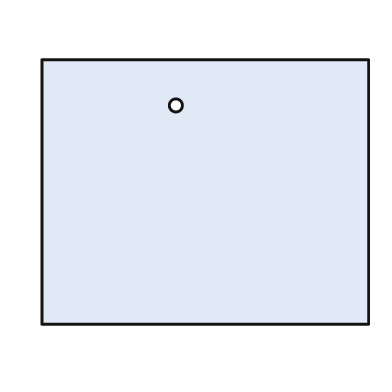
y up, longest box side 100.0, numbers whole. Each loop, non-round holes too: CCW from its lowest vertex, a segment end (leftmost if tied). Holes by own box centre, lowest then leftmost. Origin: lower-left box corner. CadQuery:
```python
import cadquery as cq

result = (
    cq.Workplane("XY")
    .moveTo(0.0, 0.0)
    .lineTo(100.0, 0.0)
    .lineTo(100.0, 81.0)
    .lineTo(0.0, 81.0)
    .close()
    .moveTo(41.0, 67.0)
    .circle(2.0)
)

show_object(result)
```